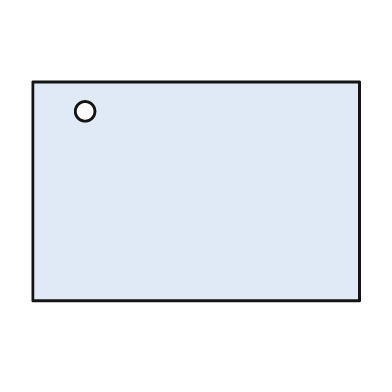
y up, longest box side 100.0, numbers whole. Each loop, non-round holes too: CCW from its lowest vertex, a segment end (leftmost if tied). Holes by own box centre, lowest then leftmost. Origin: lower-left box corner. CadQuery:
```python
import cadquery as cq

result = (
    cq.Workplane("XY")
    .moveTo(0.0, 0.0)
    .lineTo(100.0, 0.0)
    .lineTo(100.0, 67.0)
    .lineTo(0.0, 67.0)
    .close()
    .moveTo(16.0, 58.0)
    .circle(3.0)
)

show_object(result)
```